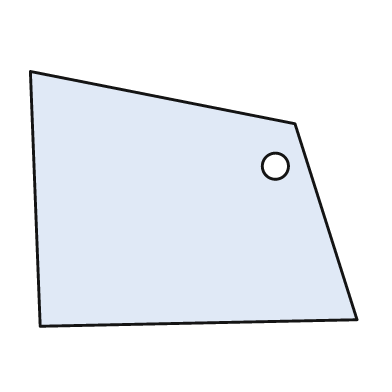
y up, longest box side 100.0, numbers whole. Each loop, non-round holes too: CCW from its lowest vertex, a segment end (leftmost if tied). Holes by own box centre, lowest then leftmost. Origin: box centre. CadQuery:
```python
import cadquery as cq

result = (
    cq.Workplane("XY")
    .moveTo(-47.0, -39.0)
    .lineTo(50.0, -37.0)
    .lineTo(31.0, 23.0)
    .lineTo(-50.0, 39.0)
    .close()
    .moveTo(25.0, 10.0)
    .circle(4.0)
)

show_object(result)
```